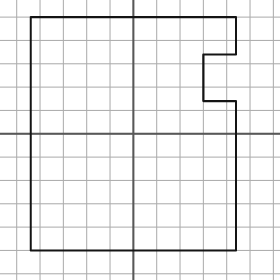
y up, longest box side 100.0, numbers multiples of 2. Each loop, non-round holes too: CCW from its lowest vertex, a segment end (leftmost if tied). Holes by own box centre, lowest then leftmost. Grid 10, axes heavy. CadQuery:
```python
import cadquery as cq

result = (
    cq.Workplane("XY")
    .moveTo(-44.0, -50.0)
    .lineTo(44.0, -50.0)
    .lineTo(44.0, 14.0)
    .lineTo(30.0, 14.0)
    .lineTo(30.0, 34.0)
    .lineTo(44.0, 34.0)
    .lineTo(44.0, 50.0)
    .lineTo(-44.0, 50.0)
    .close()
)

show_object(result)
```